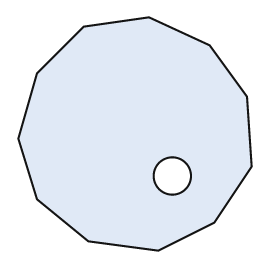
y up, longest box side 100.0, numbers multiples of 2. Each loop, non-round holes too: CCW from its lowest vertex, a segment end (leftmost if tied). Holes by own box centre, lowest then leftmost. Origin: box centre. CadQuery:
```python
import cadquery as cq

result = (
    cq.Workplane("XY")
    .moveTo(10.0, -50.0)
    .lineTo(34.0, -38.0)
    .lineTo(50.0, -14.0)
    .lineTo(48.0, 16.0)
    .lineTo(32.0, 38.0)
    .lineTo(6.0, 50.0)
    .lineTo(-22.0, 46.0)
    .lineTo(-42.0, 26.0)
    .lineTo(-50.0, -2.0)
    .lineTo(-42.0, -28.0)
    .lineTo(-20.0, -46.0)
    .close()
    .moveTo(16.0, -18.0)
    .circle(8.0)
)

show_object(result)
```